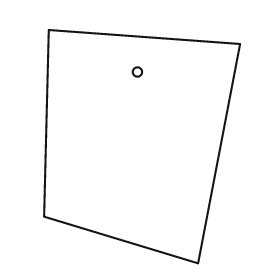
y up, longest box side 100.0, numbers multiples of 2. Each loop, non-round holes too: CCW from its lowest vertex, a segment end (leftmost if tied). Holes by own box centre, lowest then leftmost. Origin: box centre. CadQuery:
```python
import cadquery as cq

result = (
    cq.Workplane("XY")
    .moveTo(24.0, -50.0)
    .lineTo(42.0, 44.0)
    .lineTo(-40.0, 50.0)
    .lineTo(-42.0, -30.0)
    .close()
    .moveTo(-2.0, 32.0)
    .circle(2.0)
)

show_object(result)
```